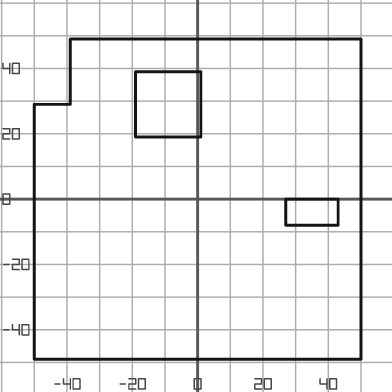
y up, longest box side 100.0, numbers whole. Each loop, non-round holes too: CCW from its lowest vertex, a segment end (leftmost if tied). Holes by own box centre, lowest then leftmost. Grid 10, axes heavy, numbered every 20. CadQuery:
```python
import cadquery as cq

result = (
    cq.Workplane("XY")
    .moveTo(-50.0, -49.0)
    .lineTo(50.0, -49.0)
    .lineTo(50.0, 49.0)
    .lineTo(-39.0, 49.0)
    .lineTo(-39.0, 29.0)
    .lineTo(-50.0, 29.0)
    .close()
    .moveTo(27.0, -8.0)
    .lineTo(43.0, -8.0)
    .lineTo(43.0, 0.0)
    .lineTo(27.0, 0.0)
    .close()
    .moveTo(-19.0, 19.0)
    .lineTo(1.0, 19.0)
    .lineTo(1.0, 39.0)
    .lineTo(-19.0, 39.0)
    .close()
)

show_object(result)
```